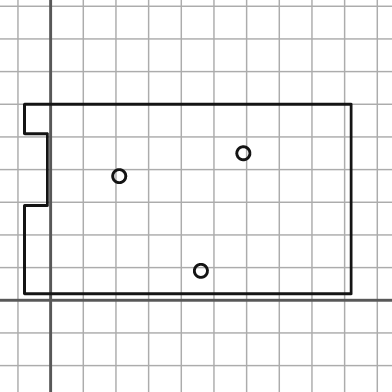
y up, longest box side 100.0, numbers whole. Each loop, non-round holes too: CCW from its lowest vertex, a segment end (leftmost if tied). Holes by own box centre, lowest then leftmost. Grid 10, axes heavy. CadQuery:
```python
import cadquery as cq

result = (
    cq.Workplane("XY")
    .moveTo(-8.0, 2.0)
    .lineTo(92.0, 2.0)
    .lineTo(92.0, 60.0)
    .lineTo(-8.0, 60.0)
    .lineTo(-8.0, 51.0)
    .lineTo(-1.0, 51.0)
    .lineTo(-1.0, 29.0)
    .lineTo(-8.0, 29.0)
    .close()
    .moveTo(46.0, 9.0)
    .circle(2.0)
    .moveTo(21.0, 38.0)
    .circle(2.0)
    .moveTo(59.0, 45.0)
    .circle(2.0)
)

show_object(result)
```